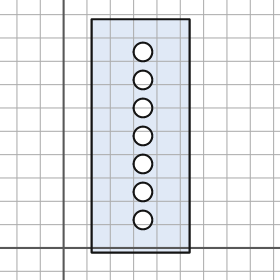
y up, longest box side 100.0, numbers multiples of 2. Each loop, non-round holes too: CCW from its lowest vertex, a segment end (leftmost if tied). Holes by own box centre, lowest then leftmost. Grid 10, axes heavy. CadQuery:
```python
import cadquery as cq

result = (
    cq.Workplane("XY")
    .moveTo(12.0, -2.0)
    .lineTo(54.0, -2.0)
    .lineTo(54.0, 98.0)
    .lineTo(12.0, 98.0)
    .close()
    .moveTo(34.0, 12.0)
    .circle(4.0)
    .moveTo(34.0, 24.0)
    .circle(4.0)
    .moveTo(34.0, 36.0)
    .circle(4.0)
    .moveTo(34.0, 48.0)
    .circle(4.0)
    .moveTo(34.0, 60.0)
    .circle(4.0)
    .moveTo(34.0, 72.0)
    .circle(4.0)
    .moveTo(34.0, 84.0)
    .circle(4.0)
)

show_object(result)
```